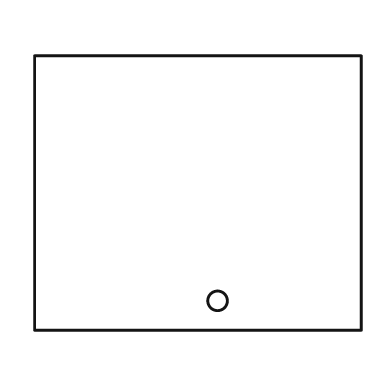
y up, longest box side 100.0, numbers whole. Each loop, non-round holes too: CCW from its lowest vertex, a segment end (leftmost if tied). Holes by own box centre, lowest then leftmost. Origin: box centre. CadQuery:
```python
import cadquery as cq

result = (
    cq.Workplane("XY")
    .moveTo(-50.0, -42.0)
    .lineTo(50.0, -42.0)
    .lineTo(50.0, 42.0)
    .lineTo(-50.0, 42.0)
    .close()
    .moveTo(6.0, -33.0)
    .circle(3.0)
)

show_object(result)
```